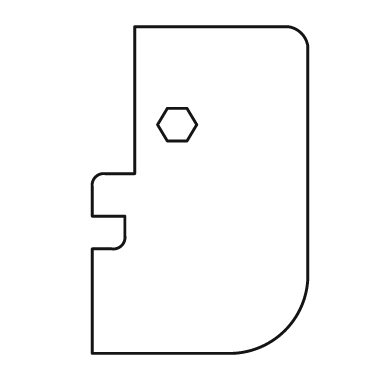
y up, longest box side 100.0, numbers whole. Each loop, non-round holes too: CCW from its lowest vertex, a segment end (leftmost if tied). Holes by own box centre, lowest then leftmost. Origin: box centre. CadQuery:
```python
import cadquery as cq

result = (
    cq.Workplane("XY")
    .moveTo(-33.0, -50.0)
    .lineTo(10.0, -50.0)
    .threePointArc((26.0, -43.0), (33.0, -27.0))
    .lineTo(33.0, 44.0)
    .threePointArc((31.0, 48.0), (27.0, 50.0))
    .lineTo(-20.0, 50.0)
    .lineTo(-20.0, 5.0)
    .lineTo(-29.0, 5.0)
    .threePointArc((-32.0, 4.0), (-33.0, 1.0))
    .lineTo(-33.0, -8.0)
    .lineTo(-23.0, -8.0)
    .lineTo(-23.0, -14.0)
    .threePointArc((-24.0, -17.0), (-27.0, -18.0))
    .lineTo(-33.0, -18.0)
    .close()
    .moveTo(-10.0, 15.0)
    .lineTo(-4.0, 15.0)
    .lineTo(-1.0, 20.0)
    .lineTo(-4.0, 25.0)
    .lineTo(-10.0, 25.0)
    .lineTo(-13.0, 20.0)
    .close()
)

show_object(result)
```